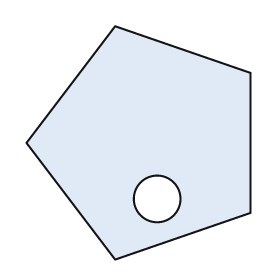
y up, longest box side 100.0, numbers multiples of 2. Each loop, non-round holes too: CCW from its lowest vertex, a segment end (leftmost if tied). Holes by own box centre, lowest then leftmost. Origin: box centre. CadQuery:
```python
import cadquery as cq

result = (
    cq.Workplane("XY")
    .moveTo(-10.0, -50.0)
    .lineTo(48.0, -30.0)
    .lineTo(48.0, 30.0)
    .lineTo(-10.0, 50.0)
    .lineTo(-48.0, 0.0)
    .close()
    .moveTo(8.0, -24.0)
    .circle(10.0)
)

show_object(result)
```